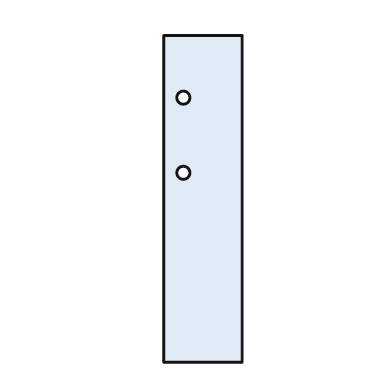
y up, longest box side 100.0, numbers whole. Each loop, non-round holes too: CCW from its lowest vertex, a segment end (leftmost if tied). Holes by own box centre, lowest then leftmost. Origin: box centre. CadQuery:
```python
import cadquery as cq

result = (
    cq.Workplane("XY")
    .moveTo(-12.0, -50.0)
    .lineTo(12.0, -50.0)
    .lineTo(12.0, 50.0)
    .lineTo(-12.0, 50.0)
    .close()
    .moveTo(-6.0, 8.0)
    .circle(2.0)
    .moveTo(-6.0, 31.0)
    .circle(2.0)
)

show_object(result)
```